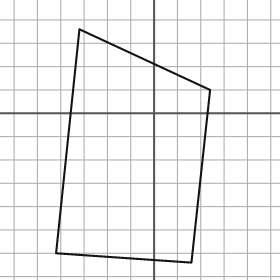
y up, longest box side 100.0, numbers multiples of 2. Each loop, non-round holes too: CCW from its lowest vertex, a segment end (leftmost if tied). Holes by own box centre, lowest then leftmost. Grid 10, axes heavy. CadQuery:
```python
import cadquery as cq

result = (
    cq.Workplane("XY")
    .moveTo(16.0, -64.0)
    .lineTo(24.0, 10.0)
    .lineTo(-32.0, 36.0)
    .lineTo(-42.0, -60.0)
    .close()
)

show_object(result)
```